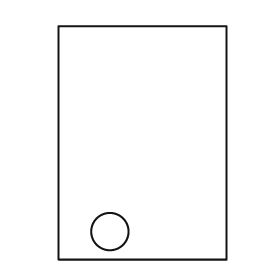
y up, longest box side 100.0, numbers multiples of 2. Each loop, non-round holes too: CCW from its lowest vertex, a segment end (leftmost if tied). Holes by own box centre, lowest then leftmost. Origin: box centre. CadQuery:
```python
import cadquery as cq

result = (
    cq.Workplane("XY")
    .moveTo(-36.0, -50.0)
    .lineTo(36.0, -50.0)
    .lineTo(36.0, 50.0)
    .lineTo(-36.0, 50.0)
    .close()
    .moveTo(-14.0, -38.0)
    .circle(8.0)
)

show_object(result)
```